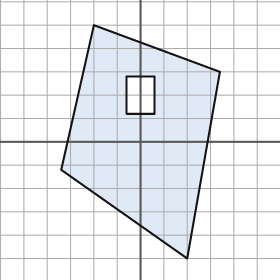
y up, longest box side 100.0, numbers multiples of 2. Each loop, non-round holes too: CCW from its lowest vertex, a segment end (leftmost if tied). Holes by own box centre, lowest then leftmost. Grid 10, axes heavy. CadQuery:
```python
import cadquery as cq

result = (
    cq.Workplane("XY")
    .moveTo(20.0, -50.0)
    .lineTo(34.0, 30.0)
    .lineTo(-20.0, 50.0)
    .lineTo(-34.0, -12.0)
    .close()
    .moveTo(-6.0, 12.0)
    .lineTo(6.0, 12.0)
    .lineTo(6.0, 28.0)
    .lineTo(-6.0, 28.0)
    .close()
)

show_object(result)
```